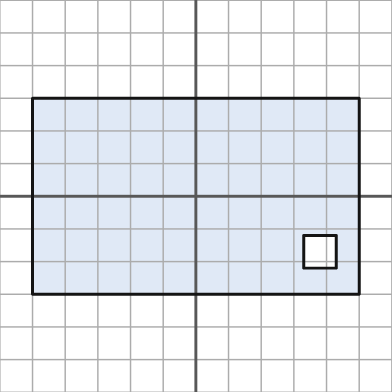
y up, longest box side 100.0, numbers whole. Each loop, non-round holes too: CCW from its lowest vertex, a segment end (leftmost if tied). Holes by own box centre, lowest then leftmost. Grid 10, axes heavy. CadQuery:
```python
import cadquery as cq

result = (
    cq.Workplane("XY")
    .moveTo(-50.0, -30.0)
    .lineTo(50.0, -30.0)
    .lineTo(50.0, 30.0)
    .lineTo(-50.0, 30.0)
    .close()
    .moveTo(33.0, -22.0)
    .lineTo(43.0, -22.0)
    .lineTo(43.0, -12.0)
    .lineTo(33.0, -12.0)
    .close()
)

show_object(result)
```